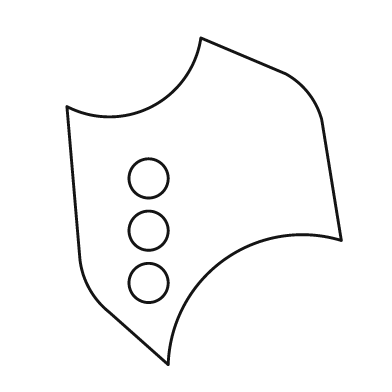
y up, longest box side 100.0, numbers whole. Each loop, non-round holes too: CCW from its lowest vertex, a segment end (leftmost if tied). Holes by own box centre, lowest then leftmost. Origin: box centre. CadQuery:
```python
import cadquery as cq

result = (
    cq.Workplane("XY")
    .moveTo(-11.0, -50.0)
    .threePointArc((6.0, -18.0), (42.0, -12.0))
    .lineTo(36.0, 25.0)
    .threePointArc((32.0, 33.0), (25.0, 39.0))
    .lineTo(-1.0, 50.0)
    .threePointArc((-16.0, 29.0), (-42.0, 29.0))
    .lineTo(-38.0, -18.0)
    .threePointArc((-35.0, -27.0), (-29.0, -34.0))
    .close()
    .moveTo(-17.0, -25.0)
    .circle(6.0)
    .moveTo(-17.0, -9.0)
    .circle(6.0)
    .moveTo(-17.0, 7.0)
    .circle(6.0)
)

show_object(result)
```